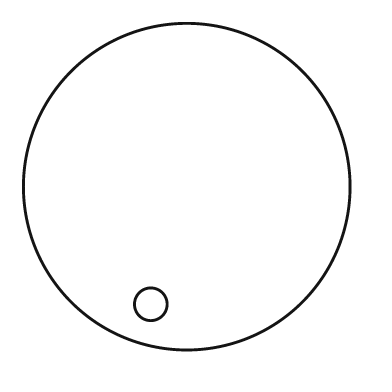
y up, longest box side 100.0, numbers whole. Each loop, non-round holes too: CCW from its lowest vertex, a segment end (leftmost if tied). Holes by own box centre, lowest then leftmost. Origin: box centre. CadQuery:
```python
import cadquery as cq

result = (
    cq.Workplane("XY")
    .moveTo(0.0, 0.0)
    .circle(50.0)
    .moveTo(-11.0, -36.0)
    .circle(5.0)
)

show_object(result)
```